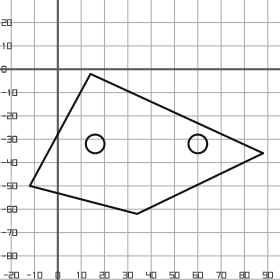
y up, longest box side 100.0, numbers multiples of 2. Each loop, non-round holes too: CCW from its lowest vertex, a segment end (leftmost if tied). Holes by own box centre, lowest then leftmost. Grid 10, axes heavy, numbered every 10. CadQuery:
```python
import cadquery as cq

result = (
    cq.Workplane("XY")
    .moveTo(34.0, -62.0)
    .lineTo(88.0, -36.0)
    .lineTo(14.0, -2.0)
    .lineTo(-12.0, -50.0)
    .close()
    .moveTo(16.0, -32.0)
    .circle(4.0)
    .moveTo(60.0, -32.0)
    .circle(4.0)
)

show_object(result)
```